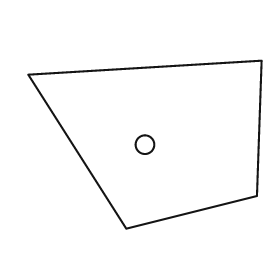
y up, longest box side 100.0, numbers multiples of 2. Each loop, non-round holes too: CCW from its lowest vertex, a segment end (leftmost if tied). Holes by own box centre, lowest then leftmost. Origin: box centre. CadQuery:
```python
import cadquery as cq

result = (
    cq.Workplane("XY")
    .moveTo(-8.0, -36.0)
    .lineTo(48.0, -22.0)
    .lineTo(50.0, 36.0)
    .lineTo(-50.0, 30.0)
    .close()
    .moveTo(0.0, 0.0)
    .circle(4.0)
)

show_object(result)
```